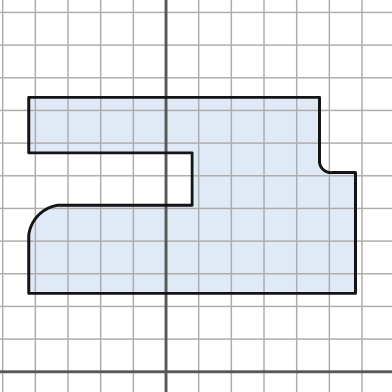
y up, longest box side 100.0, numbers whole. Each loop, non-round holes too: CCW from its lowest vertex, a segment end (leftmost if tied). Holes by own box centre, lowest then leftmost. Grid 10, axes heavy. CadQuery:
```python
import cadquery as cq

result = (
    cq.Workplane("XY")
    .moveTo(-42.0, 24.0)
    .lineTo(58.0, 24.0)
    .lineTo(58.0, 61.0)
    .lineTo(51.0, 61.0)
    .threePointArc((48.0, 62.0), (47.0, 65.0))
    .lineTo(47.0, 84.0)
    .lineTo(-42.0, 84.0)
    .lineTo(-42.0, 67.0)
    .lineTo(8.0, 67.0)
    .lineTo(8.0, 51.0)
    .lineTo(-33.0, 51.0)
    .threePointArc((-39.0, 48.0), (-42.0, 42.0))
    .close()
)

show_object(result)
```